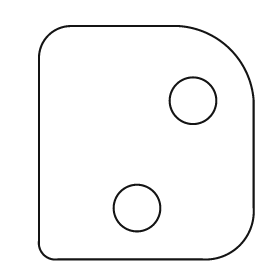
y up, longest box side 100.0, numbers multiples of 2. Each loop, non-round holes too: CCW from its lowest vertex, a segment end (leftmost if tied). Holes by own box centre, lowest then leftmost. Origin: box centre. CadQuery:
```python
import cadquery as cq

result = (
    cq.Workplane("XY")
    .moveTo(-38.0, -50.0)
    .lineTo(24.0, -50.0)
    .threePointArc((40.0, -44.0), (46.0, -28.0))
    .lineTo(46.0, 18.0)
    .threePointArc((36.0, 40.0), (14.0, 50.0))
    .lineTo(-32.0, 50.0)
    .threePointArc((-42.0, 46.0), (-46.0, 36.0))
    .lineTo(-46.0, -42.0)
    .threePointArc((-44.0, -48.0), (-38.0, -50.0))
    .close()
    .moveTo(-4.0, -28.0)
    .circle(10.0)
    .moveTo(20.0, 18.0)
    .circle(10.0)
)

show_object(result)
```